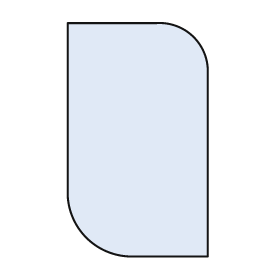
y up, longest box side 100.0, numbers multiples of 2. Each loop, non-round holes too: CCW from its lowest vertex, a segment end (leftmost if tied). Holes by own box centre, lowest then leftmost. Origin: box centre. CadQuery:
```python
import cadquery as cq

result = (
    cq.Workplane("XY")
    .moveTo(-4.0, -50.0)
    .lineTo(30.0, -50.0)
    .lineTo(30.0, 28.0)
    .threePointArc((24.0, 44.0), (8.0, 50.0))
    .lineTo(-30.0, 50.0)
    .lineTo(-30.0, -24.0)
    .threePointArc((-22.0, -42.0), (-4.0, -50.0))
    .close()
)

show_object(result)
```